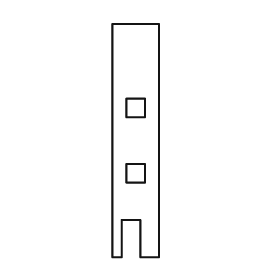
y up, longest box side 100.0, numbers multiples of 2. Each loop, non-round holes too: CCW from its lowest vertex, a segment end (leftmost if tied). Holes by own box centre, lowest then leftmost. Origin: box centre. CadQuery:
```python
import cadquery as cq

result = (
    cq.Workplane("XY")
    .moveTo(-10.0, -50.0)
    .lineTo(-6.0, -50.0)
    .lineTo(-6.0, -34.0)
    .lineTo(2.0, -34.0)
    .lineTo(2.0, -50.0)
    .lineTo(10.0, -50.0)
    .lineTo(10.0, 50.0)
    .lineTo(-10.0, 50.0)
    .close()
    .moveTo(-4.0, -18.0)
    .lineTo(4.0, -18.0)
    .lineTo(4.0, -10.0)
    .lineTo(-4.0, -10.0)
    .close()
    .moveTo(-4.0, 10.0)
    .lineTo(4.0, 10.0)
    .lineTo(4.0, 18.0)
    .lineTo(-4.0, 18.0)
    .close()
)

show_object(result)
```